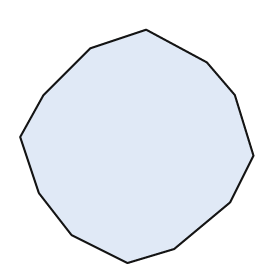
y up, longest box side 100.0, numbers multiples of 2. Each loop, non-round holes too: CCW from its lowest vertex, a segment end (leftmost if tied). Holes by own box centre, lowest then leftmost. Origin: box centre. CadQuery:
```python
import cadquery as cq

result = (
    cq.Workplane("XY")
    .moveTo(-4.0, -50.0)
    .lineTo(16.0, -44.0)
    .lineTo(40.0, -24.0)
    .lineTo(50.0, -4.0)
    .lineTo(42.0, 22.0)
    .lineTo(30.0, 36.0)
    .lineTo(4.0, 50.0)
    .lineTo(-20.0, 42.0)
    .lineTo(-40.0, 22.0)
    .lineTo(-50.0, 4.0)
    .lineTo(-42.0, -20.0)
    .lineTo(-28.0, -38.0)
    .close()
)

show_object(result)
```